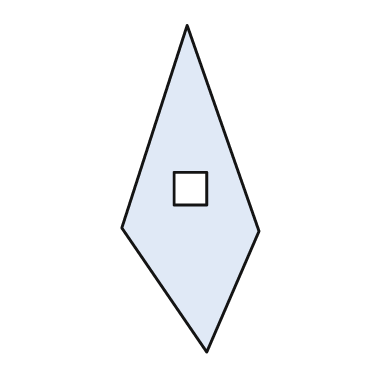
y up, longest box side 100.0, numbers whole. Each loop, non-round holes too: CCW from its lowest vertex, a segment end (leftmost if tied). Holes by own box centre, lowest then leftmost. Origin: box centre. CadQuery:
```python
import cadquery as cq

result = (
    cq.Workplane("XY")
    .moveTo(5.0, -50.0)
    .lineTo(21.0, -13.0)
    .lineTo(-1.0, 50.0)
    .lineTo(-21.0, -12.0)
    .close()
    .moveTo(-5.0, -5.0)
    .lineTo(5.0, -5.0)
    .lineTo(5.0, 5.0)
    .lineTo(-5.0, 5.0)
    .close()
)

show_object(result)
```